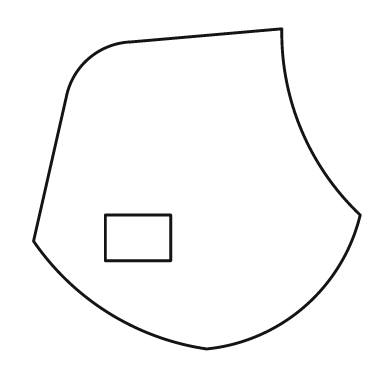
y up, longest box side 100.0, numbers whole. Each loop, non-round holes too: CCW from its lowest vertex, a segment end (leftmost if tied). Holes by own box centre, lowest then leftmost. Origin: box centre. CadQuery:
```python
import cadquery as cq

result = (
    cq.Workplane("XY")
    .moveTo(3.0, -49.0)
    .threePointArc((33.0, -36.0), (50.0, -8.0))
    .threePointArc((32.0, 18.0), (26.0, 49.0))
    .lineTo(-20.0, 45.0)
    .threePointArc((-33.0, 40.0), (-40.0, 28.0))
    .lineTo(-50.0, -16.0)
    .threePointArc((-27.0, -38.0), (3.0, -49.0))
    .close()
    .moveTo(-28.0, -22.0)
    .lineTo(-8.0, -22.0)
    .lineTo(-8.0, -8.0)
    .lineTo(-28.0, -8.0)
    .close()
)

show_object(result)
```